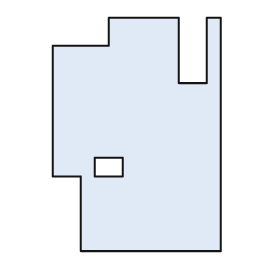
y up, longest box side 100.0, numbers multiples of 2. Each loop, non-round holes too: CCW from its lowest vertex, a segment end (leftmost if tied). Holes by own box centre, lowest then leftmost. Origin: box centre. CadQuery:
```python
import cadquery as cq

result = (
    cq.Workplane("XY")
    .moveTo(-24.0, -50.0)
    .lineTo(36.0, -50.0)
    .lineTo(36.0, 50.0)
    .lineTo(30.0, 50.0)
    .lineTo(30.0, 22.0)
    .lineTo(18.0, 22.0)
    .lineTo(18.0, 50.0)
    .lineTo(-12.0, 50.0)
    .lineTo(-12.0, 38.0)
    .lineTo(-36.0, 38.0)
    .lineTo(-36.0, -18.0)
    .lineTo(-24.0, -18.0)
    .close()
    .moveTo(-18.0, -18.0)
    .lineTo(-6.0, -18.0)
    .lineTo(-6.0, -10.0)
    .lineTo(-18.0, -10.0)
    .close()
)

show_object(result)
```